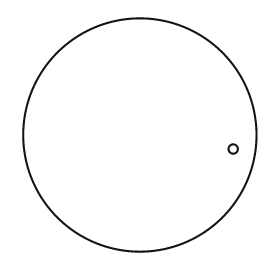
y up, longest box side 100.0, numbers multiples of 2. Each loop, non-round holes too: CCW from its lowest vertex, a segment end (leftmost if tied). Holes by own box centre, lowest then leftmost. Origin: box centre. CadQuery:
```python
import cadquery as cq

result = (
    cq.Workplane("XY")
    .moveTo(0.0, 0.0)
    .circle(50.0)
    .moveTo(40.0, -6.0)
    .circle(2.0)
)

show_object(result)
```